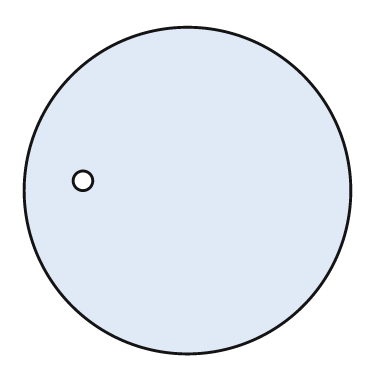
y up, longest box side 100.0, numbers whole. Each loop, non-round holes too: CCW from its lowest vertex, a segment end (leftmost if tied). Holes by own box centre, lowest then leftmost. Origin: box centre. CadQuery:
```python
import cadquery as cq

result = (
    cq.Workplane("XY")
    .moveTo(0.0, 0.0)
    .circle(50.0)
    .moveTo(-32.0, 3.0)
    .circle(3.0)
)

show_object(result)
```